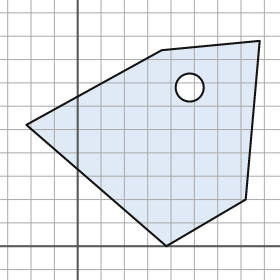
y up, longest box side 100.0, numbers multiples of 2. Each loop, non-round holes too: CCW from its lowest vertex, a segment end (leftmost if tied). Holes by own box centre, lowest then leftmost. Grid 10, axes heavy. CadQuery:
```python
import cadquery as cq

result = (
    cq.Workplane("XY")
    .moveTo(38.0, 0.0)
    .lineTo(72.0, 20.0)
    .lineTo(78.0, 88.0)
    .lineTo(36.0, 84.0)
    .lineTo(-22.0, 52.0)
    .close()
    .moveTo(48.0, 68.0)
    .circle(6.0)
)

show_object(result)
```